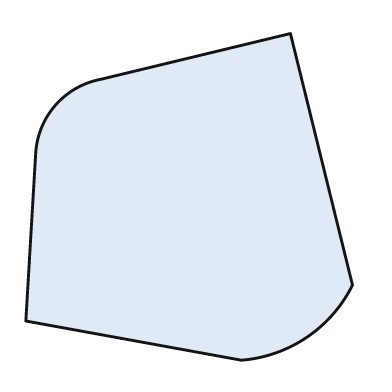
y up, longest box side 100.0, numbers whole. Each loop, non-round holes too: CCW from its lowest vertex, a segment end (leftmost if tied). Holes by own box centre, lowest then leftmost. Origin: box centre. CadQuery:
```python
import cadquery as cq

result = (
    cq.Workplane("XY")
    .moveTo(16.0, -50.0)
    .threePointArc((36.0, -43.0), (50.0, -27.0))
    .lineTo(31.0, 50.0)
    .lineTo(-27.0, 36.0)
    .threePointArc((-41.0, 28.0), (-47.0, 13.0))
    .lineTo(-50.0, -38.0)
    .close()
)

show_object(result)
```